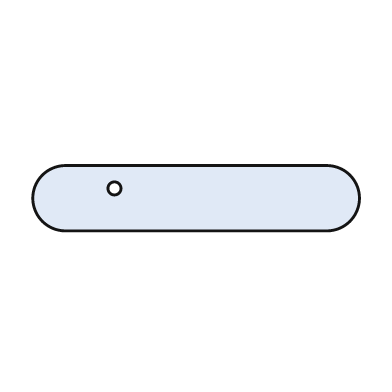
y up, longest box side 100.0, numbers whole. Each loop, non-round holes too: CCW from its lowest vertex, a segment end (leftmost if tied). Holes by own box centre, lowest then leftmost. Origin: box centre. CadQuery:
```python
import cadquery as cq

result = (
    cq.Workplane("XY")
    .moveTo(-40.0, -10.0)
    .lineTo(40.0, -10.0)
    .threePointArc((50.0, 0.0), (40.0, 10.0))
    .lineTo(-40.0, 10.0)
    .threePointArc((-50.0, 0.0), (-40.0, -10.0))
    .close()
    .moveTo(-25.0, 3.0)
    .circle(2.0)
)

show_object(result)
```